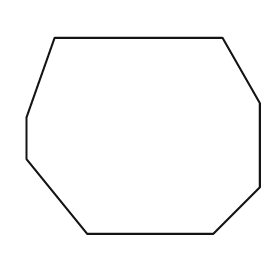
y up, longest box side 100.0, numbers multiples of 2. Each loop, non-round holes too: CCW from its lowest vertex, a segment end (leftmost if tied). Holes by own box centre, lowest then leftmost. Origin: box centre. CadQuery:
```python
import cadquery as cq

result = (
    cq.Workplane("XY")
    .moveTo(-24.0, -42.0)
    .lineTo(30.0, -42.0)
    .lineTo(50.0, -22.0)
    .lineTo(50.0, 14.0)
    .lineTo(34.0, 42.0)
    .lineTo(-38.0, 42.0)
    .lineTo(-50.0, 8.0)
    .lineTo(-50.0, -10.0)
    .close()
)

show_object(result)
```